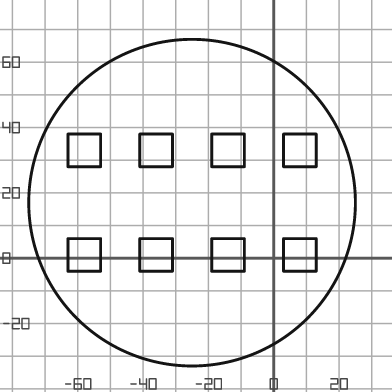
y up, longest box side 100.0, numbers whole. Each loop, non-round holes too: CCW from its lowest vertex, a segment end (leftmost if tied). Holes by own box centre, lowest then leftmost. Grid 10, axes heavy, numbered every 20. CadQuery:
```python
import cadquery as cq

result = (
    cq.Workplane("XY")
    .moveTo(-25.0, 17.0)
    .circle(50.0)
    .moveTo(-63.0, -4.0)
    .lineTo(-53.0, -4.0)
    .lineTo(-53.0, 6.0)
    .lineTo(-63.0, 6.0)
    .close()
    .moveTo(-41.0, -4.0)
    .lineTo(-31.0, -4.0)
    .lineTo(-31.0, 6.0)
    .lineTo(-41.0, 6.0)
    .close()
    .moveTo(-19.0, -4.0)
    .lineTo(-9.0, -4.0)
    .lineTo(-9.0, 6.0)
    .lineTo(-19.0, 6.0)
    .close()
    .moveTo(3.0, -4.0)
    .lineTo(13.0, -4.0)
    .lineTo(13.0, 6.0)
    .lineTo(3.0, 6.0)
    .close()
    .moveTo(-63.0, 28.0)
    .lineTo(-53.0, 28.0)
    .lineTo(-53.0, 38.0)
    .lineTo(-63.0, 38.0)
    .close()
    .moveTo(-41.0, 28.0)
    .lineTo(-31.0, 28.0)
    .lineTo(-31.0, 38.0)
    .lineTo(-41.0, 38.0)
    .close()
    .moveTo(-19.0, 28.0)
    .lineTo(-9.0, 28.0)
    .lineTo(-9.0, 38.0)
    .lineTo(-19.0, 38.0)
    .close()
    .moveTo(3.0, 28.0)
    .lineTo(13.0, 28.0)
    .lineTo(13.0, 38.0)
    .lineTo(3.0, 38.0)
    .close()
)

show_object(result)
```